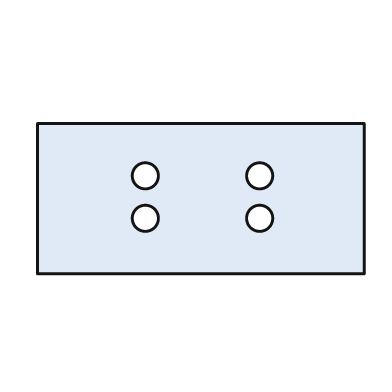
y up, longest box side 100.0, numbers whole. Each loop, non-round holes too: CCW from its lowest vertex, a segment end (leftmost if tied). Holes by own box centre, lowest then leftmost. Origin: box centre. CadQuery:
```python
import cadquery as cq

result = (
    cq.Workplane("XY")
    .moveTo(-50.0, -23.0)
    .lineTo(50.0, -23.0)
    .lineTo(50.0, 23.0)
    .lineTo(-50.0, 23.0)
    .close()
    .moveTo(-17.0, -6.0)
    .circle(4.0)
    .moveTo(18.0, -6.0)
    .circle(4.0)
    .moveTo(-17.0, 7.0)
    .circle(4.0)
    .moveTo(18.0, 7.0)
    .circle(4.0)
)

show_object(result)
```